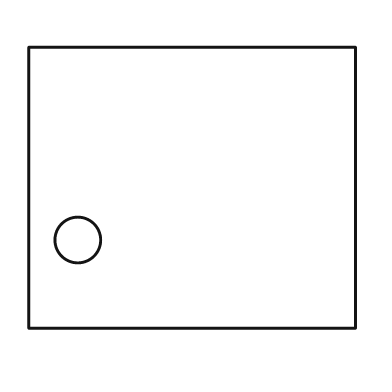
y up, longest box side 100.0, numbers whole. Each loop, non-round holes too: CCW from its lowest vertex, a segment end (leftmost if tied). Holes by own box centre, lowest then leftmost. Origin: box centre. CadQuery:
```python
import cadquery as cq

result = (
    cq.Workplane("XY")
    .moveTo(-50.0, -43.0)
    .lineTo(50.0, -43.0)
    .lineTo(50.0, 43.0)
    .lineTo(-50.0, 43.0)
    .close()
    .moveTo(-35.0, -16.0)
    .circle(7.0)
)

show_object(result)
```